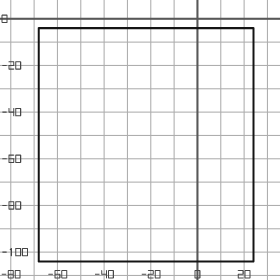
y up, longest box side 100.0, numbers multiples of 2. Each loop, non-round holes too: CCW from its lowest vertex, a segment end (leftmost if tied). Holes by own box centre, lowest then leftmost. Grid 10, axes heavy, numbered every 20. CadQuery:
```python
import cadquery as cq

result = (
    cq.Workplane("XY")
    .moveTo(-68.0, -104.0)
    .lineTo(24.0, -104.0)
    .lineTo(24.0, -4.0)
    .lineTo(-68.0, -4.0)
    .close()
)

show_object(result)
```